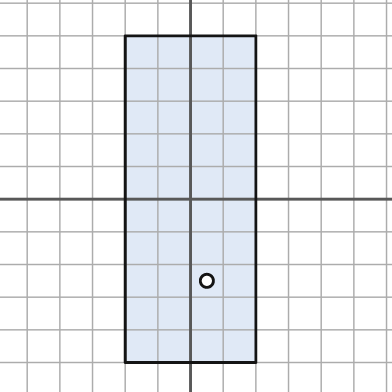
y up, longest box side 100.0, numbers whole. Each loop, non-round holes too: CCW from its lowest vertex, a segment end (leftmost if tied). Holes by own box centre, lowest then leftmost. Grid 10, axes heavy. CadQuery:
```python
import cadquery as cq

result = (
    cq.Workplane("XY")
    .moveTo(-20.0, -50.0)
    .lineTo(20.0, -50.0)
    .lineTo(20.0, 50.0)
    .lineTo(-20.0, 50.0)
    .close()
    .moveTo(5.0, -25.0)
    .circle(2.0)
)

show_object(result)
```